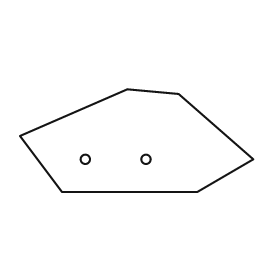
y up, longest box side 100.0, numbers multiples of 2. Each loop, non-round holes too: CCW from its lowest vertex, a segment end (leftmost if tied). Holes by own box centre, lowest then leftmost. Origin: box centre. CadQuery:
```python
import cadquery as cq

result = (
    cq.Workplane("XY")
    .moveTo(-32.0, -22.0)
    .lineTo(26.0, -22.0)
    .lineTo(50.0, -8.0)
    .lineTo(18.0, 20.0)
    .lineTo(-4.0, 22.0)
    .lineTo(-50.0, 2.0)
    .close()
    .moveTo(-22.0, -8.0)
    .circle(2.0)
    .moveTo(4.0, -8.0)
    .circle(2.0)
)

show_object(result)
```